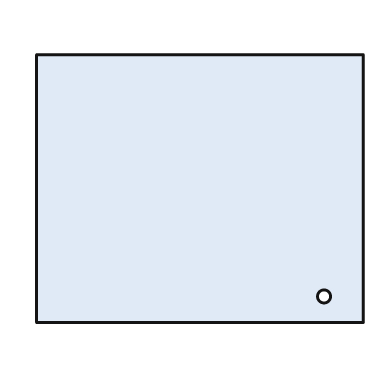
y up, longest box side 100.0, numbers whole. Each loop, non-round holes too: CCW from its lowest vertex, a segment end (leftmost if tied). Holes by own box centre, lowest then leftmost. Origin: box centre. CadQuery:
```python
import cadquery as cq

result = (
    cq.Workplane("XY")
    .moveTo(-50.0, -41.0)
    .lineTo(50.0, -41.0)
    .lineTo(50.0, 41.0)
    .lineTo(-50.0, 41.0)
    .close()
    .moveTo(38.0, -33.0)
    .circle(2.0)
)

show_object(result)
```